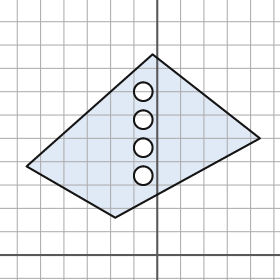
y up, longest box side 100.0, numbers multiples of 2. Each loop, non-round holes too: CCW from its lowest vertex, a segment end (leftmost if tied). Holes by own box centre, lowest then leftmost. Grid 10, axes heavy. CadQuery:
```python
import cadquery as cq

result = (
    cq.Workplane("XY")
    .moveTo(-18.0, 16.0)
    .lineTo(44.0, 50.0)
    .lineTo(-2.0, 86.0)
    .lineTo(-56.0, 38.0)
    .close()
    .moveTo(-6.0, 34.0)
    .circle(4.0)
    .moveTo(-6.0, 46.0)
    .circle(4.0)
    .moveTo(-6.0, 58.0)
    .circle(4.0)
    .moveTo(-6.0, 70.0)
    .circle(4.0)
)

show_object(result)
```